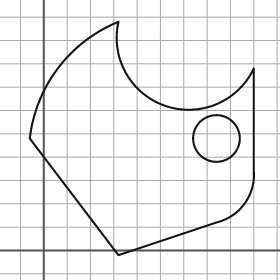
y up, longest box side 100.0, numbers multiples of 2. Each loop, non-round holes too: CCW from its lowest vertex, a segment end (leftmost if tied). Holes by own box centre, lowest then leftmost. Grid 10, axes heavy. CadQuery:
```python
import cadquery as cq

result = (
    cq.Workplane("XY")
    .moveTo(32.0, -2.0)
    .lineTo(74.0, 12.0)
    .threePointArc((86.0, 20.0), (90.0, 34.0))
    .lineTo(90.0, 78.0)
    .threePointArc((52.0, 62.0), (32.0, 98.0))
    .threePointArc((6.0, 78.0), (-6.0, 48.0))
    .close()
    .moveTo(74.0, 48.0)
    .circle(10.0)
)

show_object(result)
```